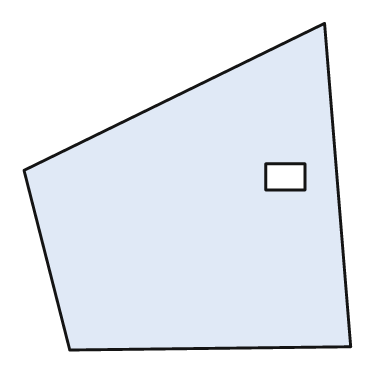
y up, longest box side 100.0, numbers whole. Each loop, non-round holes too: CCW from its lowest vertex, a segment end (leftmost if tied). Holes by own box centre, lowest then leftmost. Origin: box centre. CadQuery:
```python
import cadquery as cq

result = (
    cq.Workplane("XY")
    .moveTo(-36.0, -50.0)
    .lineTo(50.0, -49.0)
    .lineTo(42.0, 50.0)
    .lineTo(-50.0, 5.0)
    .close()
    .moveTo(24.0, -1.0)
    .lineTo(36.0, -1.0)
    .lineTo(36.0, 7.0)
    .lineTo(24.0, 7.0)
    .close()
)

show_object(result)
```